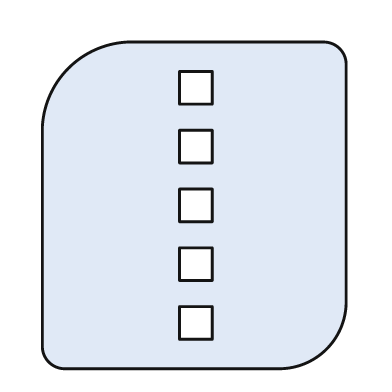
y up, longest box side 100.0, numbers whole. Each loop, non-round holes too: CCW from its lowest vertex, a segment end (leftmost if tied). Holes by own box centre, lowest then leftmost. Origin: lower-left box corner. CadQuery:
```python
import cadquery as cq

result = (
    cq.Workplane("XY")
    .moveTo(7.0, 0.0)
    .lineTo(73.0, 0.0)
    .threePointArc((87.0, 6.0), (93.0, 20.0))
    .lineTo(93.0, 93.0)
    .threePointArc((91.0, 98.0), (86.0, 100.0))
    .lineTo(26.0, 100.0)
    .threePointArc((8.0, 92.0), (0.0, 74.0))
    .lineTo(0.0, 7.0)
    .threePointArc((2.0, 2.0), (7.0, 0.0))
    .close()
    .moveTo(42.0, 9.0)
    .lineTo(52.0, 9.0)
    .lineTo(52.0, 19.0)
    .lineTo(42.0, 19.0)
    .close()
    .moveTo(42.0, 27.0)
    .lineTo(52.0, 27.0)
    .lineTo(52.0, 37.0)
    .lineTo(42.0, 37.0)
    .close()
    .moveTo(42.0, 45.0)
    .lineTo(52.0, 45.0)
    .lineTo(52.0, 55.0)
    .lineTo(42.0, 55.0)
    .close()
    .moveTo(42.0, 63.0)
    .lineTo(52.0, 63.0)
    .lineTo(52.0, 73.0)
    .lineTo(42.0, 73.0)
    .close()
    .moveTo(42.0, 81.0)
    .lineTo(52.0, 81.0)
    .lineTo(52.0, 91.0)
    .lineTo(42.0, 91.0)
    .close()
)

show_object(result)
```